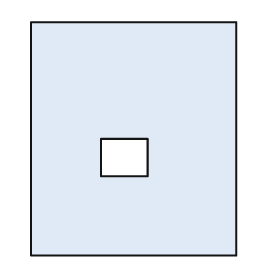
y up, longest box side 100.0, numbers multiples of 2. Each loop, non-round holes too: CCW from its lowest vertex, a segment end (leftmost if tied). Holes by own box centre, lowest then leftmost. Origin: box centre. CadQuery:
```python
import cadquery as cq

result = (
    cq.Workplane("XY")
    .moveTo(-44.0, -50.0)
    .lineTo(44.0, -50.0)
    .lineTo(44.0, 50.0)
    .lineTo(-44.0, 50.0)
    .close()
    .moveTo(-14.0, -16.0)
    .lineTo(6.0, -16.0)
    .lineTo(6.0, 0.0)
    .lineTo(-14.0, 0.0)
    .close()
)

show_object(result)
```